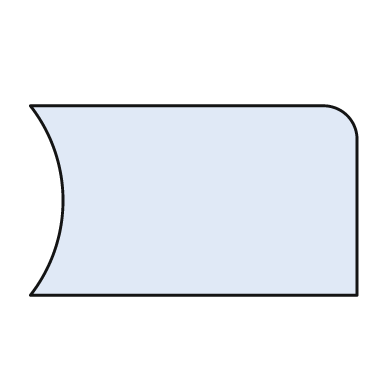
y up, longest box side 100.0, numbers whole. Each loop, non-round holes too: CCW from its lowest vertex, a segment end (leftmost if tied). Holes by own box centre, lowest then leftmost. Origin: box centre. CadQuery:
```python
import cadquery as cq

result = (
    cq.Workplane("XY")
    .moveTo(-50.0, -29.0)
    .lineTo(50.0, -29.0)
    .lineTo(50.0, 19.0)
    .threePointArc((47.0, 26.0), (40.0, 29.0))
    .lineTo(-50.0, 29.0)
    .threePointArc((-40.0, 0.0), (-50.0, -29.0))
    .close()
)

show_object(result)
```